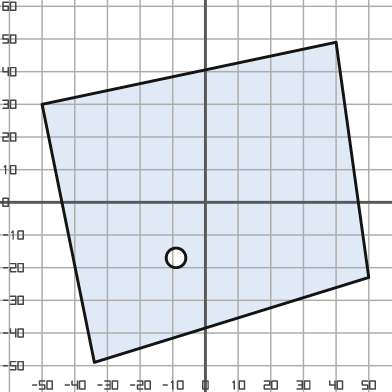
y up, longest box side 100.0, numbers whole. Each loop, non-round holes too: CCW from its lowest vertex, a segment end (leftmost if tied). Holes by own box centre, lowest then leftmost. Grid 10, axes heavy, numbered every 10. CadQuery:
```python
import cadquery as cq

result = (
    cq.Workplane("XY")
    .moveTo(-34.0, -49.0)
    .lineTo(50.0, -23.0)
    .lineTo(40.0, 49.0)
    .lineTo(-50.0, 30.0)
    .close()
    .moveTo(-9.0, -17.0)
    .circle(3.0)
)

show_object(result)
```